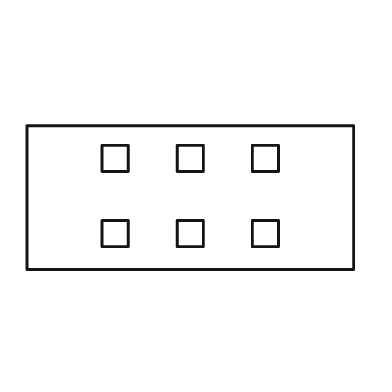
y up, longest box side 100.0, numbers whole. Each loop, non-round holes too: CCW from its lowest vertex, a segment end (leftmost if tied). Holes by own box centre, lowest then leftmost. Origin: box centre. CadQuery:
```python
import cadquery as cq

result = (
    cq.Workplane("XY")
    .moveTo(-50.0, -22.0)
    .lineTo(50.0, -22.0)
    .lineTo(50.0, 22.0)
    .lineTo(-50.0, 22.0)
    .close()
    .moveTo(-27.0, -15.0)
    .lineTo(-19.0, -15.0)
    .lineTo(-19.0, -7.0)
    .lineTo(-27.0, -7.0)
    .close()
    .moveTo(-4.0, -15.0)
    .lineTo(4.0, -15.0)
    .lineTo(4.0, -7.0)
    .lineTo(-4.0, -7.0)
    .close()
    .moveTo(19.0, -15.0)
    .lineTo(27.0, -15.0)
    .lineTo(27.0, -7.0)
    .lineTo(19.0, -7.0)
    .close()
    .moveTo(-27.0, 8.0)
    .lineTo(-19.0, 8.0)
    .lineTo(-19.0, 16.0)
    .lineTo(-27.0, 16.0)
    .close()
    .moveTo(-4.0, 8.0)
    .lineTo(4.0, 8.0)
    .lineTo(4.0, 16.0)
    .lineTo(-4.0, 16.0)
    .close()
    .moveTo(19.0, 8.0)
    .lineTo(27.0, 8.0)
    .lineTo(27.0, 16.0)
    .lineTo(19.0, 16.0)
    .close()
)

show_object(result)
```